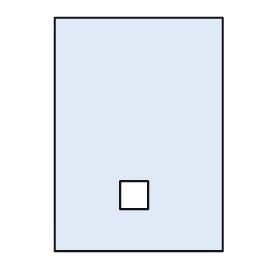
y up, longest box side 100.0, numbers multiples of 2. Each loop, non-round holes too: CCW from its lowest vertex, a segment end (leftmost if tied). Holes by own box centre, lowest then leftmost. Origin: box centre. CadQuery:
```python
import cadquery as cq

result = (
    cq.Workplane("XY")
    .moveTo(-36.0, -50.0)
    .lineTo(36.0, -50.0)
    .lineTo(36.0, 50.0)
    .lineTo(-36.0, 50.0)
    .close()
    .moveTo(-8.0, -32.0)
    .lineTo(4.0, -32.0)
    .lineTo(4.0, -20.0)
    .lineTo(-8.0, -20.0)
    .close()
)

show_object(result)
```